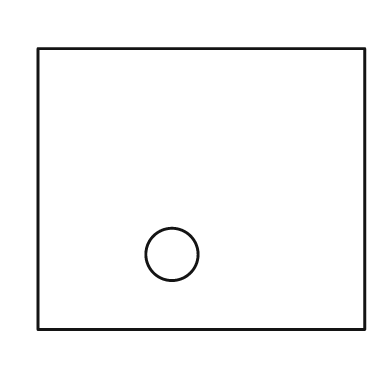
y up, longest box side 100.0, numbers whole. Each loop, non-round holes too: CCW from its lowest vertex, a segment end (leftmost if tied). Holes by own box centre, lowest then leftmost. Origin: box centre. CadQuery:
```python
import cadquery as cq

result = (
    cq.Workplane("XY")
    .moveTo(-50.0, -43.0)
    .lineTo(50.0, -43.0)
    .lineTo(50.0, 43.0)
    .lineTo(-50.0, 43.0)
    .close()
    .moveTo(-9.0, -20.0)
    .circle(8.0)
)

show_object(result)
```